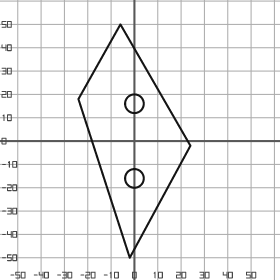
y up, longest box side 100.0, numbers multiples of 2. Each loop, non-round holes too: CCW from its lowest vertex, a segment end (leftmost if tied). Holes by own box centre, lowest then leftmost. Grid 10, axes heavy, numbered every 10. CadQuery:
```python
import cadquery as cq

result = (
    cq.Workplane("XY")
    .moveTo(-2.0, -50.0)
    .lineTo(24.0, -2.0)
    .lineTo(-6.0, 50.0)
    .lineTo(-24.0, 18.0)
    .close()
    .moveTo(0.0, -16.0)
    .circle(4.0)
    .moveTo(0.0, 16.0)
    .circle(4.0)
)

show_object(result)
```